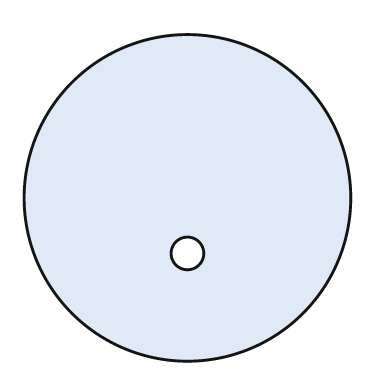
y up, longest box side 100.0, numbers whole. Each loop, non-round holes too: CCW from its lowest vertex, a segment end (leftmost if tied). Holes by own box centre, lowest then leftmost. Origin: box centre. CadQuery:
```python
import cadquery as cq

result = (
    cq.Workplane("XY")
    .moveTo(0.0, 0.0)
    .circle(50.0)
    .moveTo(0.0, -17.0)
    .circle(5.0)
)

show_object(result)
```